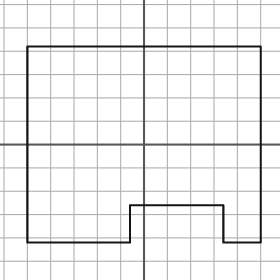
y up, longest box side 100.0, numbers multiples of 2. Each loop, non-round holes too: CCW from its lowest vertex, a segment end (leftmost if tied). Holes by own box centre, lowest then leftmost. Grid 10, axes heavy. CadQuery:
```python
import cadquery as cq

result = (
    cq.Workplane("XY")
    .moveTo(-50.0, -42.0)
    .lineTo(-6.0, -42.0)
    .lineTo(-6.0, -26.0)
    .lineTo(34.0, -26.0)
    .lineTo(34.0, -42.0)
    .lineTo(50.0, -42.0)
    .lineTo(50.0, 42.0)
    .lineTo(-50.0, 42.0)
    .close()
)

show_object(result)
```